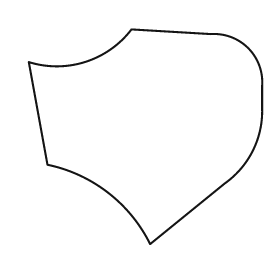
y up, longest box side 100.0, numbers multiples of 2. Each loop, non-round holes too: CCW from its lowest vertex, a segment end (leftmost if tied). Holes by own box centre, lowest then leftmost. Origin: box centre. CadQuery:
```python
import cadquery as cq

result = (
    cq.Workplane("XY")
    .moveTo(2.0, -46.0)
    .lineTo(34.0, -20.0)
    .threePointArc((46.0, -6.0), (50.0, 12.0))
    .lineTo(50.0, 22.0)
    .threePointArc((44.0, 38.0), (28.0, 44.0))
    .lineTo(-6.0, 46.0)
    .threePointArc((-26.0, 32.0), (-50.0, 32.0))
    .lineTo(-42.0, -12.0)
    .threePointArc((-16.0, -24.0), (2.0, -46.0))
    .close()
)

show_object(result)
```